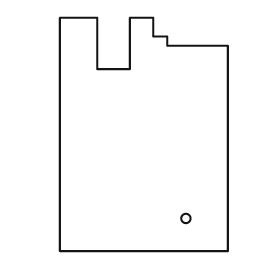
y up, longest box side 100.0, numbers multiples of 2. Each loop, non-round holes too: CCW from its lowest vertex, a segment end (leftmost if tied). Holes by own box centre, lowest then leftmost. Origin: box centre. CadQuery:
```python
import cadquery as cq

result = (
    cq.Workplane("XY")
    .moveTo(-36.0, -50.0)
    .lineTo(36.0, -50.0)
    .lineTo(36.0, 38.0)
    .lineTo(10.0, 38.0)
    .lineTo(10.0, 42.0)
    .lineTo(4.0, 42.0)
    .lineTo(4.0, 50.0)
    .lineTo(-6.0, 50.0)
    .lineTo(-6.0, 28.0)
    .lineTo(-20.0, 28.0)
    .lineTo(-20.0, 50.0)
    .lineTo(-36.0, 50.0)
    .close()
    .moveTo(18.0, -36.0)
    .circle(2.0)
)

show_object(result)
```